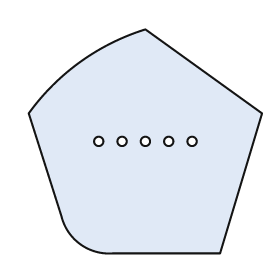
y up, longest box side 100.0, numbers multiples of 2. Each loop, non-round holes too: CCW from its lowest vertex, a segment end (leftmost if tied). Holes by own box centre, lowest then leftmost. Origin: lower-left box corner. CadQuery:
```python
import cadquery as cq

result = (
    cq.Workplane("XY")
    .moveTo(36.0, 0.0)
    .lineTo(82.0, 0.0)
    .lineTo(100.0, 60.0)
    .lineTo(50.0, 96.0)
    .threePointArc((22.0, 82.0), (0.0, 60.0))
    .lineTo(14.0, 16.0)
    .threePointArc((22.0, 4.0), (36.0, 0.0))
    .close()
    .moveTo(30.0, 48.0)
    .circle(2.0)
    .moveTo(40.0, 48.0)
    .circle(2.0)
    .moveTo(50.0, 48.0)
    .circle(2.0)
    .moveTo(60.0, 48.0)
    .circle(2.0)
    .moveTo(70.0, 48.0)
    .circle(2.0)
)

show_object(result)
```